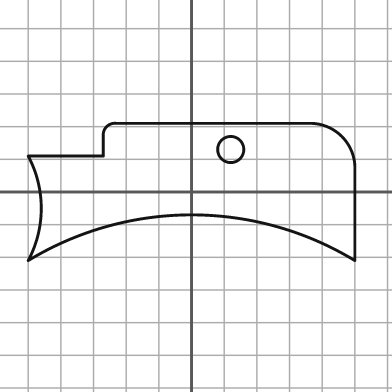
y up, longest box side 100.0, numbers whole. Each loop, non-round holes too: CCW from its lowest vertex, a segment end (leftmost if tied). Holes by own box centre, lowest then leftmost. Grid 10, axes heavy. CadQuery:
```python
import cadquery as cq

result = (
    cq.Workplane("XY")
    .moveTo(-50.0, -21.0)
    .threePointArc((0.0, -7.0), (50.0, -21.0))
    .lineTo(50.0, 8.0)
    .threePointArc((46.0, 17.0), (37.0, 21.0))
    .lineTo(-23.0, 21.0)
    .threePointArc((-26.0, 20.0), (-27.0, 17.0))
    .lineTo(-27.0, 11.0)
    .lineTo(-50.0, 11.0)
    .threePointArc((-46.0, -5.0), (-50.0, -21.0))
    .close()
    .moveTo(12.0, 13.0)
    .circle(4.0)
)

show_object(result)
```